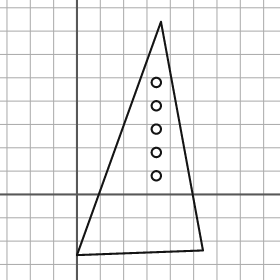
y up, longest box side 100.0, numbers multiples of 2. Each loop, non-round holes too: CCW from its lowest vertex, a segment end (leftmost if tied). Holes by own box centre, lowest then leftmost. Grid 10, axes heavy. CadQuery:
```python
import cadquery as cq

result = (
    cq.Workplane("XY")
    .moveTo(0.0, -26.0)
    .lineTo(54.0, -24.0)
    .lineTo(36.0, 74.0)
    .close()
    .moveTo(34.0, 8.0)
    .circle(2.0)
    .moveTo(34.0, 18.0)
    .circle(2.0)
    .moveTo(34.0, 28.0)
    .circle(2.0)
    .moveTo(34.0, 38.0)
    .circle(2.0)
    .moveTo(34.0, 48.0)
    .circle(2.0)
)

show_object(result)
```